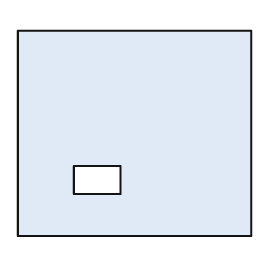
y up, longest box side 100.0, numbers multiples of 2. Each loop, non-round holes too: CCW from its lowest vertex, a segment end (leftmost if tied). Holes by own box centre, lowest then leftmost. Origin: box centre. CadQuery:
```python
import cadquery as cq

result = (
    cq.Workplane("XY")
    .moveTo(-50.0, -44.0)
    .lineTo(50.0, -44.0)
    .lineTo(50.0, 44.0)
    .lineTo(-50.0, 44.0)
    .close()
    .moveTo(-26.0, -26.0)
    .lineTo(-6.0, -26.0)
    .lineTo(-6.0, -14.0)
    .lineTo(-26.0, -14.0)
    .close()
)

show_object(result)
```